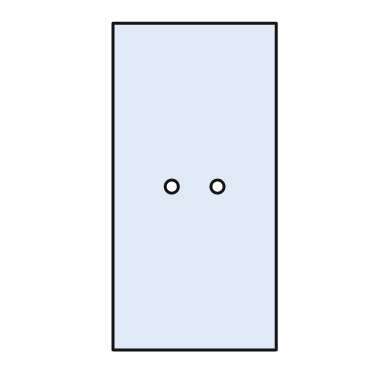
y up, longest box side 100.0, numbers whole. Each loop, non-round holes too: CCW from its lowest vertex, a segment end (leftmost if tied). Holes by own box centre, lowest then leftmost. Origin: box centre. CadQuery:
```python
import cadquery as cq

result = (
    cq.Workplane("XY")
    .moveTo(-25.0, -50.0)
    .lineTo(25.0, -50.0)
    .lineTo(25.0, 50.0)
    .lineTo(-25.0, 50.0)
    .close()
    .moveTo(-7.0, 0.0)
    .circle(2.0)
    .moveTo(7.0, 0.0)
    .circle(2.0)
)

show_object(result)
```